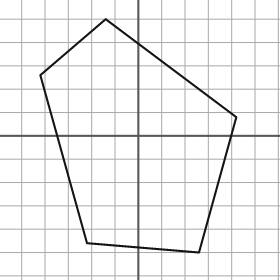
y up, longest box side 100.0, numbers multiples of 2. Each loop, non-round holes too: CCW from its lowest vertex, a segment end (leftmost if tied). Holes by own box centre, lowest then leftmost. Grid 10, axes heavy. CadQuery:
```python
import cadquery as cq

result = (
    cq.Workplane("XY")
    .moveTo(26.0, -50.0)
    .lineTo(42.0, 8.0)
    .lineTo(-14.0, 50.0)
    .lineTo(-42.0, 26.0)
    .lineTo(-22.0, -46.0)
    .close()
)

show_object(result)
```